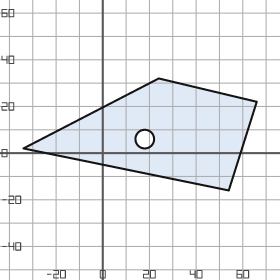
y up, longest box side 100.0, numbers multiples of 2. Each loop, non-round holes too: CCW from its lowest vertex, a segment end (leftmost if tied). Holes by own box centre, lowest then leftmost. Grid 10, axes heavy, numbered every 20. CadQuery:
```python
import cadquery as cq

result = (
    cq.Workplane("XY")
    .moveTo(54.0, -16.0)
    .lineTo(66.0, 22.0)
    .lineTo(24.0, 32.0)
    .lineTo(-34.0, 2.0)
    .close()
    .moveTo(18.0, 6.0)
    .circle(4.0)
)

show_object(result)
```